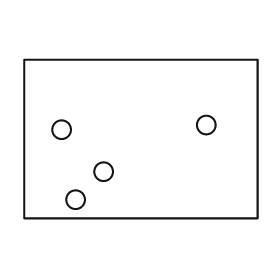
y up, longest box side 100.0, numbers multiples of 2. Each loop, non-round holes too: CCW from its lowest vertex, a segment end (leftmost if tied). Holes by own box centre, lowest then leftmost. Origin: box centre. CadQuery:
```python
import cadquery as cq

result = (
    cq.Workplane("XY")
    .moveTo(-50.0, -34.0)
    .lineTo(50.0, -34.0)
    .lineTo(50.0, 34.0)
    .lineTo(-50.0, 34.0)
    .close()
    .moveTo(-28.0, -26.0)
    .circle(4.0)
    .moveTo(-16.0, -14.0)
    .circle(4.0)
    .moveTo(-34.0, 4.0)
    .circle(4.0)
    .moveTo(28.0, 6.0)
    .circle(4.0)
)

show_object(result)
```